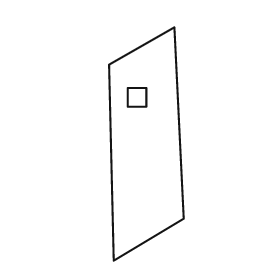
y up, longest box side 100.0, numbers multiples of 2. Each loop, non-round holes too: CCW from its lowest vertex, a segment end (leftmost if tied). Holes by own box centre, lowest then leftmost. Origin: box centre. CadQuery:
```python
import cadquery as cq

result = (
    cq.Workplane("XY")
    .moveTo(-14.0, -50.0)
    .lineTo(16.0, -32.0)
    .lineTo(12.0, 50.0)
    .lineTo(-16.0, 34.0)
    .close()
    .moveTo(-8.0, 16.0)
    .lineTo(0.0, 16.0)
    .lineTo(0.0, 24.0)
    .lineTo(-8.0, 24.0)
    .close()
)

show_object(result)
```